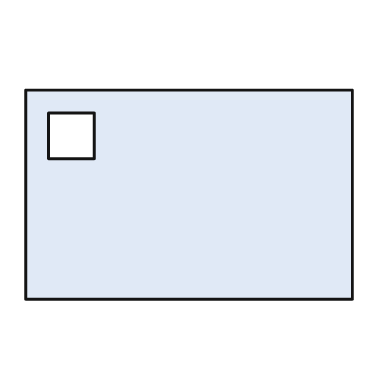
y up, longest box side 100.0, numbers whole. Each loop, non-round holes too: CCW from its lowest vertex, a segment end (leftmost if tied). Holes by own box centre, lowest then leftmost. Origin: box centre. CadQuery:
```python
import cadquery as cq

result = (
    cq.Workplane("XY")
    .moveTo(-50.0, -32.0)
    .lineTo(50.0, -32.0)
    .lineTo(50.0, 32.0)
    .lineTo(-50.0, 32.0)
    .close()
    .moveTo(-43.0, 11.0)
    .lineTo(-29.0, 11.0)
    .lineTo(-29.0, 25.0)
    .lineTo(-43.0, 25.0)
    .close()
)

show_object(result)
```